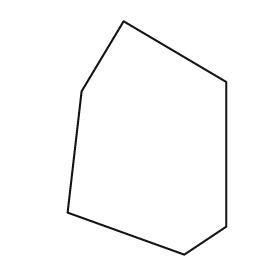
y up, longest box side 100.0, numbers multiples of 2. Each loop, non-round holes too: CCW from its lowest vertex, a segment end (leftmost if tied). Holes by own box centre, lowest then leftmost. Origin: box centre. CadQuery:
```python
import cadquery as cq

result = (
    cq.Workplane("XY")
    .moveTo(16.0, -50.0)
    .lineTo(34.0, -38.0)
    .lineTo(34.0, 24.0)
    .lineTo(-10.0, 50.0)
    .lineTo(-28.0, 20.0)
    .lineTo(-34.0, -32.0)
    .close()
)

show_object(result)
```